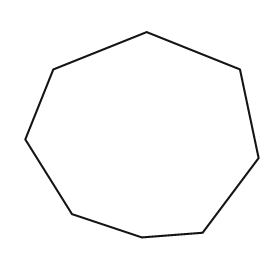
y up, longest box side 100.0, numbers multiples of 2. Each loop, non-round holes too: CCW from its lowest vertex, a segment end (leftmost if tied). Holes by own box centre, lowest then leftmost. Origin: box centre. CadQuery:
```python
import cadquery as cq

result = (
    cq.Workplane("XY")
    .moveTo(0.0, -44.0)
    .lineTo(26.0, -42.0)
    .lineTo(50.0, -10.0)
    .lineTo(42.0, 28.0)
    .lineTo(2.0, 44.0)
    .lineTo(-38.0, 28.0)
    .lineTo(-50.0, -2.0)
    .lineTo(-30.0, -34.0)
    .close()
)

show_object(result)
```